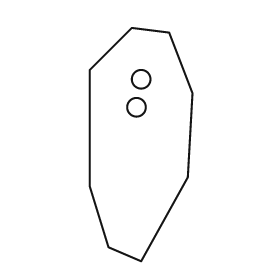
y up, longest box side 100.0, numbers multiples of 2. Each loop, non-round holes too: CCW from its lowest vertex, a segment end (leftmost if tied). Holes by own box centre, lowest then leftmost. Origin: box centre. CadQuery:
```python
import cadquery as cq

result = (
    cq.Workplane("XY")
    .moveTo(0.0, -50.0)
    .lineTo(20.0, -14.0)
    .lineTo(22.0, 22.0)
    .lineTo(12.0, 48.0)
    .lineTo(-4.0, 50.0)
    .lineTo(-22.0, 32.0)
    .lineTo(-22.0, -18.0)
    .lineTo(-14.0, -44.0)
    .close()
    .moveTo(-2.0, 16.0)
    .circle(4.0)
    .moveTo(0.0, 28.0)
    .circle(4.0)
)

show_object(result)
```